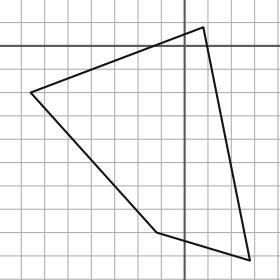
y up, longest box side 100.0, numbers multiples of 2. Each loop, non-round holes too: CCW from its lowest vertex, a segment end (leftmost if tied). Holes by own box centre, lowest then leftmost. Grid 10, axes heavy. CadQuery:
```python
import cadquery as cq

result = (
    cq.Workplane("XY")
    .moveTo(28.0, -92.0)
    .lineTo(8.0, 8.0)
    .lineTo(-66.0, -20.0)
    .lineTo(-12.0, -80.0)
    .close()
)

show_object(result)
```